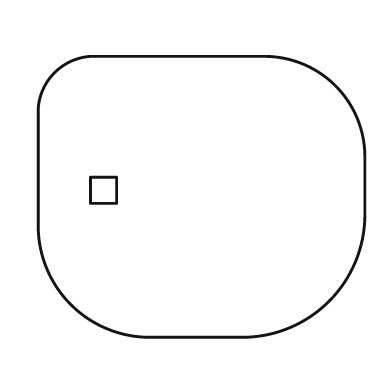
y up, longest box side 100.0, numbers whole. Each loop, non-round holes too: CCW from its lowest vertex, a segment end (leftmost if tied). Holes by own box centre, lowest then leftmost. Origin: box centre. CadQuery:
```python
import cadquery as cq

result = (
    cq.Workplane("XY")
    .moveTo(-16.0, -43.0)
    .lineTo(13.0, -43.0)
    .threePointArc((39.0, -32.0), (50.0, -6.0))
    .lineTo(50.0, 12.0)
    .threePointArc((41.0, 34.0), (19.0, 43.0))
    .lineTo(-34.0, 43.0)
    .threePointArc((-45.0, 38.0), (-50.0, 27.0))
    .lineTo(-50.0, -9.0)
    .threePointArc((-40.0, -33.0), (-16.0, -43.0))
    .close()
    .moveTo(-34.0, -2.0)
    .lineTo(-26.0, -2.0)
    .lineTo(-26.0, 6.0)
    .lineTo(-34.0, 6.0)
    .close()
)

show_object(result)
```